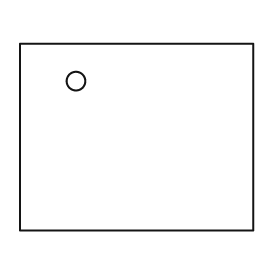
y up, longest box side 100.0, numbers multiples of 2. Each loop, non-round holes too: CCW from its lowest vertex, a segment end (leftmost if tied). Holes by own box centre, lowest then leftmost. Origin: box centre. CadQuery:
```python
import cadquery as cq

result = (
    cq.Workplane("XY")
    .moveTo(-50.0, -40.0)
    .lineTo(50.0, -40.0)
    .lineTo(50.0, 40.0)
    .lineTo(-50.0, 40.0)
    .close()
    .moveTo(-26.0, 24.0)
    .circle(4.0)
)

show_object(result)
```